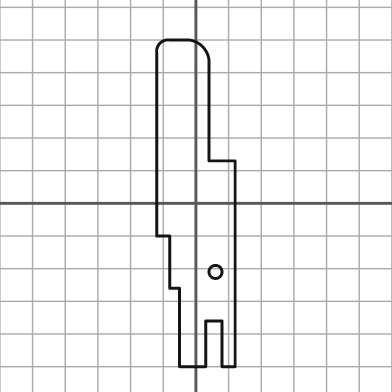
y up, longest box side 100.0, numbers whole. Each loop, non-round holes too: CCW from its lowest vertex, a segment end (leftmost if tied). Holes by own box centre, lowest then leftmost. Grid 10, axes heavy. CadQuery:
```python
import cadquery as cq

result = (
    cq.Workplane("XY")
    .moveTo(-5.0, -50.0)
    .lineTo(3.0, -50.0)
    .lineTo(3.0, -36.0)
    .lineTo(8.0, -36.0)
    .lineTo(8.0, -50.0)
    .lineTo(12.0, -50.0)
    .lineTo(12.0, 13.0)
    .lineTo(4.0, 13.0)
    .lineTo(4.0, 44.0)
    .threePointArc((2.0, 48.0), (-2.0, 50.0))
    .lineTo(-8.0, 50.0)
    .threePointArc((-11.0, 49.0), (-12.0, 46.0))
    .lineTo(-12.0, -10.0)
    .lineTo(-8.0, -10.0)
    .lineTo(-8.0, -26.0)
    .lineTo(-5.0, -26.0)
    .close()
    .moveTo(6.0, -21.0)
    .circle(2.0)
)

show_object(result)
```